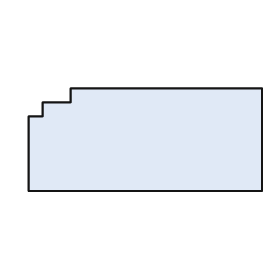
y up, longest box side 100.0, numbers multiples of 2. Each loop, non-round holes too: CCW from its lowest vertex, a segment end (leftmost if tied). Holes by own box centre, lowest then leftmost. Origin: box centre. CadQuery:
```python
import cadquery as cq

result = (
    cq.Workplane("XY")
    .moveTo(-50.0, -22.0)
    .lineTo(50.0, -22.0)
    .lineTo(50.0, 22.0)
    .lineTo(-32.0, 22.0)
    .lineTo(-32.0, 16.0)
    .lineTo(-44.0, 16.0)
    .lineTo(-44.0, 10.0)
    .lineTo(-50.0, 10.0)
    .close()
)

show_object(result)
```